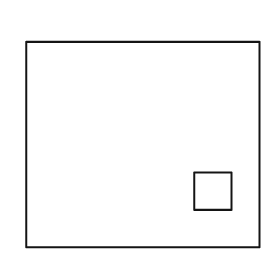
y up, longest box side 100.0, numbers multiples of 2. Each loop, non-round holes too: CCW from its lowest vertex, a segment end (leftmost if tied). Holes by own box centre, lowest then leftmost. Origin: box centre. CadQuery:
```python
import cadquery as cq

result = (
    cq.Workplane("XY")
    .moveTo(-50.0, -44.0)
    .lineTo(50.0, -44.0)
    .lineTo(50.0, 44.0)
    .lineTo(-50.0, 44.0)
    .close()
    .moveTo(22.0, -28.0)
    .lineTo(38.0, -28.0)
    .lineTo(38.0, -12.0)
    .lineTo(22.0, -12.0)
    .close()
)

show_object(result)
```